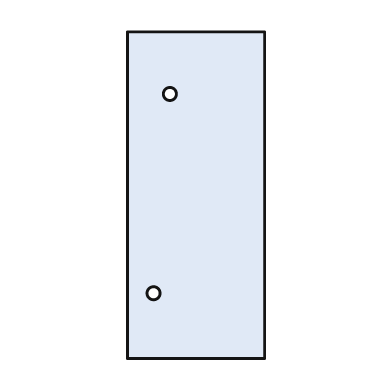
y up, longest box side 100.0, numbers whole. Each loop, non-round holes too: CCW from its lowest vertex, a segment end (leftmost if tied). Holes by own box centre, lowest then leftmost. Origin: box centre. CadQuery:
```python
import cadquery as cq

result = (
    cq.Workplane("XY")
    .moveTo(-21.0, -50.0)
    .lineTo(21.0, -50.0)
    .lineTo(21.0, 50.0)
    .lineTo(-21.0, 50.0)
    .close()
    .moveTo(-13.0, -30.0)
    .circle(2.0)
    .moveTo(-8.0, 31.0)
    .circle(2.0)
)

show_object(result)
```